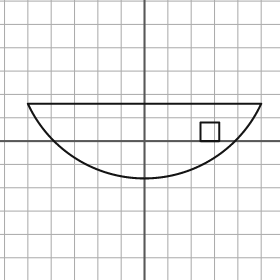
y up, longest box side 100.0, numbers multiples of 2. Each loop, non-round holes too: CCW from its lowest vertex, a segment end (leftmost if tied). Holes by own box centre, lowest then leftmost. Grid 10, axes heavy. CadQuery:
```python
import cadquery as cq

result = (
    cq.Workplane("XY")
    .moveTo(-50.0, 16.0)
    .threePointArc((0.0, -16.0), (50.0, 16.0))
    .close()
    .moveTo(24.0, 0.0)
    .lineTo(32.0, 0.0)
    .lineTo(32.0, 8.0)
    .lineTo(24.0, 8.0)
    .close()
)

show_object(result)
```